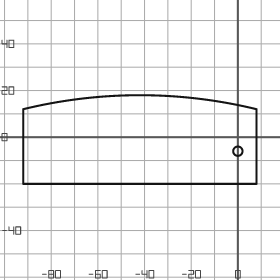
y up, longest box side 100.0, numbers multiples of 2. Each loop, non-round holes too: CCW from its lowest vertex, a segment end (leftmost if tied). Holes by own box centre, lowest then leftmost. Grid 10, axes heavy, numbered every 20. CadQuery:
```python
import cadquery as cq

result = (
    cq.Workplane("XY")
    .moveTo(-92.0, -20.0)
    .lineTo(8.0, -20.0)
    .lineTo(8.0, 12.0)
    .threePointArc((-42.0, 18.0), (-92.0, 12.0))
    .close()
    .moveTo(0.0, -6.0)
    .circle(2.0)
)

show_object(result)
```